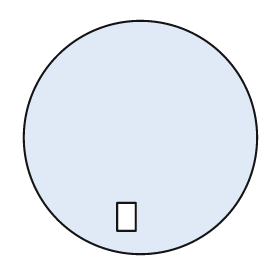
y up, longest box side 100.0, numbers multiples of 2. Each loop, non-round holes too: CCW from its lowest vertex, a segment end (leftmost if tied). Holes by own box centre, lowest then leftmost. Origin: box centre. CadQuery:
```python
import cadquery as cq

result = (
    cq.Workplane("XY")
    .moveTo(0.0, 0.0)
    .circle(50.0)
    .moveTo(-10.0, -40.0)
    .lineTo(-2.0, -40.0)
    .lineTo(-2.0, -28.0)
    .lineTo(-10.0, -28.0)
    .close()
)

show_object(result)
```